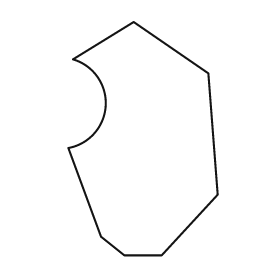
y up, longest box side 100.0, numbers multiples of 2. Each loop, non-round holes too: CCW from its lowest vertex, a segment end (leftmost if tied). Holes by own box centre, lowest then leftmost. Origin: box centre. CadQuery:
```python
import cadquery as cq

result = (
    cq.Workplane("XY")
    .moveTo(-8.0, -50.0)
    .lineTo(8.0, -50.0)
    .lineTo(32.0, -24.0)
    .lineTo(28.0, 28.0)
    .lineTo(-4.0, 50.0)
    .lineTo(-30.0, 34.0)
    .threePointArc((-16.0, 14.0), (-32.0, -4.0))
    .lineTo(-18.0, -42.0)
    .close()
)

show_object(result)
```